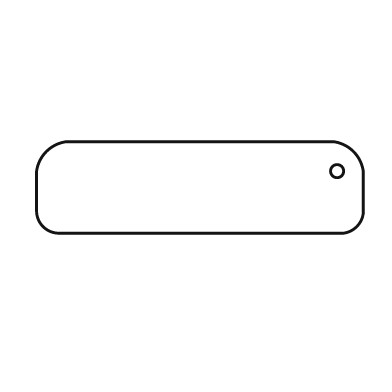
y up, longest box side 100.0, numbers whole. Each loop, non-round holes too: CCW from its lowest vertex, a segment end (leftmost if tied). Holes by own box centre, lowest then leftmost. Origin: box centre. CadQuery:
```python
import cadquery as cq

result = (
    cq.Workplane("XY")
    .moveTo(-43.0, -14.0)
    .lineTo(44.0, -14.0)
    .threePointArc((48.0, -12.0), (50.0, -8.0))
    .lineTo(50.0, 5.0)
    .threePointArc((47.0, 11.0), (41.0, 14.0))
    .lineTo(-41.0, 14.0)
    .threePointArc((-47.0, 11.0), (-50.0, 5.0))
    .lineTo(-50.0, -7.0)
    .threePointArc((-48.0, -12.0), (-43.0, -14.0))
    .close()
    .moveTo(42.0, 5.0)
    .circle(2.0)
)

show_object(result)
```